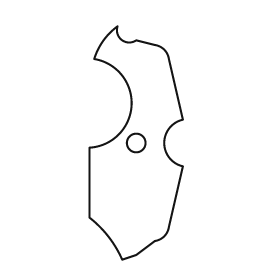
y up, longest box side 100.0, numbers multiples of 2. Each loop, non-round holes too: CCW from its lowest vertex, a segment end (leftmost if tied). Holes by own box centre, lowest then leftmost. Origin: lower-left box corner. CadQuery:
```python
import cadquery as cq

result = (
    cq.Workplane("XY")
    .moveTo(14.0, 0.0)
    .lineTo(20.0, 2.0)
    .lineTo(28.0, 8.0)
    .threePointArc((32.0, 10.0), (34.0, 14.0))
    .lineTo(40.0, 40.0)
    .threePointArc((32.0, 50.0), (40.0, 60.0))
    .lineTo(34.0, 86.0)
    .threePointArc((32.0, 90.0), (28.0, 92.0))
    .lineTo(20.0, 94.0)
    .threePointArc((14.0, 94.0), (12.0, 100.0))
    .threePointArc((6.0, 94.0), (2.0, 86.0))
    .threePointArc((18.0, 66.0), (0.0, 48.0))
    .lineTo(0.0, 18.0)
    .threePointArc((8.0, 10.0), (14.0, 0.0))
    .close()
    .moveTo(20.0, 50.0)
    .circle(4.0)
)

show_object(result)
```